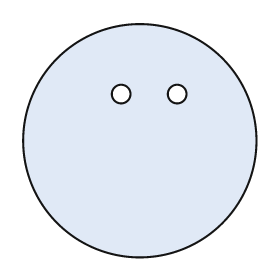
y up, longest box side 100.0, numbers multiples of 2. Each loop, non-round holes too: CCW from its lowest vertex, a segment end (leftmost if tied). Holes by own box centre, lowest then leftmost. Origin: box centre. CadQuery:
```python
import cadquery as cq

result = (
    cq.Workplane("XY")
    .moveTo(0.0, 0.0)
    .circle(50.0)
    .moveTo(-8.0, 20.0)
    .circle(4.0)
    .moveTo(16.0, 20.0)
    .circle(4.0)
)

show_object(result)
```